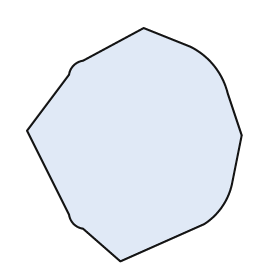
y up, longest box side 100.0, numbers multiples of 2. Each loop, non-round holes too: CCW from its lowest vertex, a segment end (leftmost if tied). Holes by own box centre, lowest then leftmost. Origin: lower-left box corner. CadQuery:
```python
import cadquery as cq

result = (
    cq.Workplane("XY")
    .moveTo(40.0, 0.0)
    .lineTo(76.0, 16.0)
    .threePointArc((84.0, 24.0), (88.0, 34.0))
    .lineTo(92.0, 54.0)
    .lineTo(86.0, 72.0)
    .threePointArc((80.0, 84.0), (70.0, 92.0))
    .lineTo(50.0, 100.0)
    .lineTo(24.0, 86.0)
    .threePointArc((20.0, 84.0), (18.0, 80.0))
    .lineTo(0.0, 56.0)
    .lineTo(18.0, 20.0)
    .threePointArc((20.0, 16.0), (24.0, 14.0))
    .close()
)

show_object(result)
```